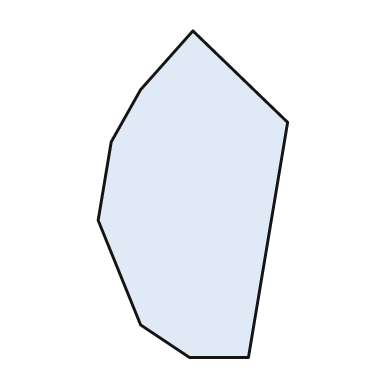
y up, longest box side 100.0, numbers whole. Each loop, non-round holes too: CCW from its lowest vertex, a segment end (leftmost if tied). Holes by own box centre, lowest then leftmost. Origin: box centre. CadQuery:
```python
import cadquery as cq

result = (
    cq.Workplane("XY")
    .moveTo(-1.0, -50.0)
    .lineTo(17.0, -50.0)
    .lineTo(29.0, 22.0)
    .lineTo(0.0, 50.0)
    .lineTo(-16.0, 32.0)
    .lineTo(-25.0, 16.0)
    .lineTo(-29.0, -8.0)
    .lineTo(-16.0, -40.0)
    .close()
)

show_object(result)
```